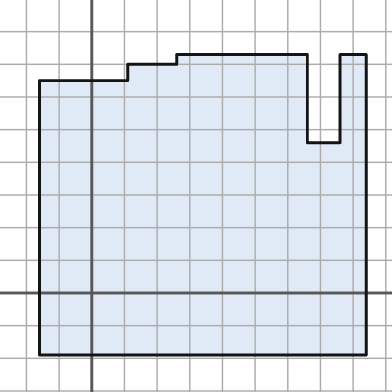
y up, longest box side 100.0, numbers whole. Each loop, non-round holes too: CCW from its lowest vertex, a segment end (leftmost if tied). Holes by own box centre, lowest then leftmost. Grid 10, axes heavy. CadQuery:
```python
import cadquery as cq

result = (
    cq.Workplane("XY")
    .moveTo(-16.0, -19.0)
    .lineTo(84.0, -19.0)
    .lineTo(84.0, 73.0)
    .lineTo(76.0, 73.0)
    .lineTo(76.0, 46.0)
    .lineTo(66.0, 46.0)
    .lineTo(66.0, 73.0)
    .lineTo(26.0, 73.0)
    .lineTo(26.0, 70.0)
    .lineTo(11.0, 70.0)
    .lineTo(11.0, 65.0)
    .lineTo(-16.0, 65.0)
    .close()
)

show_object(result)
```